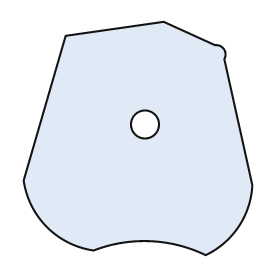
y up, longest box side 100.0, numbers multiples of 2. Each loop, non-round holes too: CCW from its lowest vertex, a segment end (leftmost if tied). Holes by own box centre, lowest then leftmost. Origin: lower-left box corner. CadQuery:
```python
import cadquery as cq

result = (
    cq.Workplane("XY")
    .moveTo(78.0, 0.0)
    .threePointArc((92.0, 12.0), (98.0, 30.0))
    .lineTo(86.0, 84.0)
    .threePointArc((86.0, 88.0), (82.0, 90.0))
    .lineTo(60.0, 100.0)
    .lineTo(18.0, 94.0)
    .lineTo(0.0, 32.0)
    .threePointArc((10.0, 12.0), (30.0, 2.0))
    .threePointArc((54.0, 6.0), (78.0, 0.0))
    .close()
    .moveTo(52.0, 56.0)
    .circle(6.0)
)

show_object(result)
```